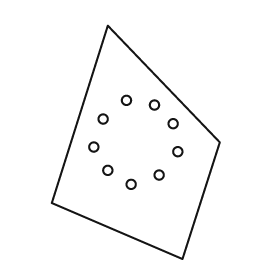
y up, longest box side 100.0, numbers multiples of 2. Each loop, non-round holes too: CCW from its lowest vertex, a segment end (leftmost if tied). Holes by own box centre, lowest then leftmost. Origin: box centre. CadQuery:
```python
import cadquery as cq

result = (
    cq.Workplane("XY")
    .moveTo(20.0, -50.0)
    .lineTo(36.0, 0.0)
    .lineTo(-12.0, 50.0)
    .lineTo(-36.0, -26.0)
    .close()
    .moveTo(-2.0, -18.0)
    .circle(2.0)
    .moveTo(10.0, -14.0)
    .circle(2.0)
    .moveTo(-12.0, -12.0)
    .circle(2.0)
    .moveTo(18.0, -4.0)
    .circle(2.0)
    .moveTo(-18.0, -2.0)
    .circle(2.0)
    .moveTo(16.0, 8.0)
    .circle(2.0)
    .moveTo(-14.0, 10.0)
    .circle(2.0)
    .moveTo(8.0, 16.0)
    .circle(2.0)
    .moveTo(-4.0, 18.0)
    .circle(2.0)
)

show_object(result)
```